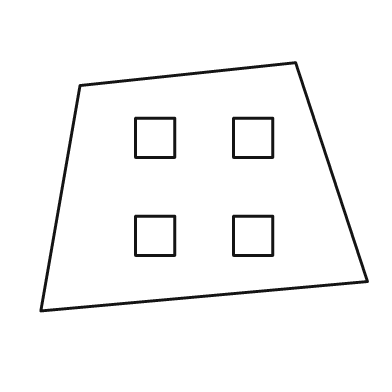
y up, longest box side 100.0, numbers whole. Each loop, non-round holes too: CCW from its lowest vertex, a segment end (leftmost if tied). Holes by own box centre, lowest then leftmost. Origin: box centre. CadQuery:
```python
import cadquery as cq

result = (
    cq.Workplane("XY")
    .moveTo(-50.0, -38.0)
    .lineTo(50.0, -29.0)
    .lineTo(28.0, 38.0)
    .lineTo(-38.0, 31.0)
    .close()
    .moveTo(-21.0, -21.0)
    .lineTo(-9.0, -21.0)
    .lineTo(-9.0, -9.0)
    .lineTo(-21.0, -9.0)
    .close()
    .moveTo(9.0, -21.0)
    .lineTo(21.0, -21.0)
    .lineTo(21.0, -9.0)
    .lineTo(9.0, -9.0)
    .close()
    .moveTo(-21.0, 9.0)
    .lineTo(-9.0, 9.0)
    .lineTo(-9.0, 21.0)
    .lineTo(-21.0, 21.0)
    .close()
    .moveTo(9.0, 9.0)
    .lineTo(21.0, 9.0)
    .lineTo(21.0, 21.0)
    .lineTo(9.0, 21.0)
    .close()
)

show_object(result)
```